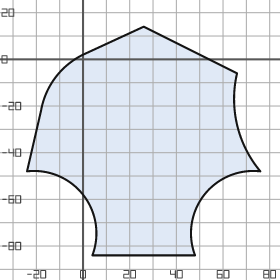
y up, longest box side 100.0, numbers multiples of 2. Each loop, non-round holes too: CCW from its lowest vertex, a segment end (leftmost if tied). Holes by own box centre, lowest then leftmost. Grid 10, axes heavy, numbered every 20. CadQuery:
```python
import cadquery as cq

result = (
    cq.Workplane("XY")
    .moveTo(4.0, -84.0)
    .lineTo(48.0, -84.0)
    .threePointArc((52.0, -58.0), (76.0, -48.0))
    .threePointArc((66.0, -28.0), (66.0, -6.0))
    .lineTo(26.0, 14.0)
    .lineTo(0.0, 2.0)
    .threePointArc((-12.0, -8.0), (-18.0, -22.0))
    .lineTo(-24.0, -48.0)
    .threePointArc((0.0, -58.0), (4.0, -84.0))
    .close()
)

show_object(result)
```